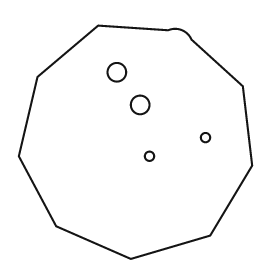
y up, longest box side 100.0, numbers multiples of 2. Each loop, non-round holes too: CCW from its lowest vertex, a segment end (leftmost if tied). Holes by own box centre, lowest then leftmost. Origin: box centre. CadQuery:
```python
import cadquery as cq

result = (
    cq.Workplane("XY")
    .moveTo(-2.0, -50.0)
    .lineTo(32.0, -40.0)
    .lineTo(50.0, -10.0)
    .lineTo(46.0, 24.0)
    .lineTo(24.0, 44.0)
    .threePointArc((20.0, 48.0), (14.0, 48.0))
    .lineTo(-16.0, 50.0)
    .lineTo(-42.0, 28.0)
    .lineTo(-50.0, -6.0)
    .lineTo(-34.0, -36.0)
    .close()
    .moveTo(6.0, -6.0)
    .circle(2.0)
    .moveTo(30.0, 2.0)
    .circle(2.0)
    .moveTo(2.0, 16.0)
    .circle(4.0)
    .moveTo(-8.0, 30.0)
    .circle(4.0)
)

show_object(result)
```